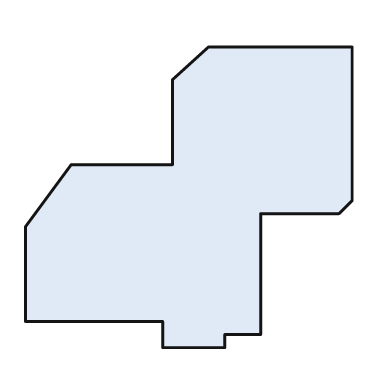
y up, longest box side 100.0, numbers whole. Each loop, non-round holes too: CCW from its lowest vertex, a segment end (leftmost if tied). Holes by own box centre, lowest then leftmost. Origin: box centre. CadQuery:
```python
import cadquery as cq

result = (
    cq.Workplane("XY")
    .moveTo(-8.0, -46.0)
    .lineTo(11.0, -46.0)
    .lineTo(11.0, -42.0)
    .lineTo(22.0, -42.0)
    .lineTo(22.0, -5.0)
    .lineTo(46.0, -5.0)
    .lineTo(50.0, -1.0)
    .lineTo(50.0, 46.0)
    .lineTo(6.0, 46.0)
    .lineTo(-5.0, 36.0)
    .lineTo(-5.0, 10.0)
    .lineTo(-36.0, 10.0)
    .lineTo(-50.0, -9.0)
    .lineTo(-50.0, -38.0)
    .lineTo(-8.0, -38.0)
    .close()
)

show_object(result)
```